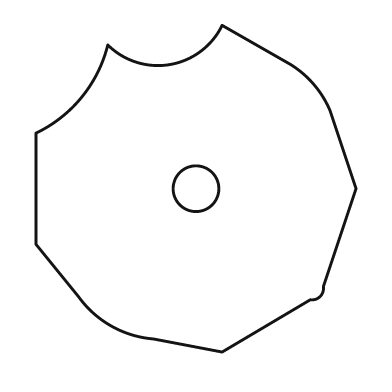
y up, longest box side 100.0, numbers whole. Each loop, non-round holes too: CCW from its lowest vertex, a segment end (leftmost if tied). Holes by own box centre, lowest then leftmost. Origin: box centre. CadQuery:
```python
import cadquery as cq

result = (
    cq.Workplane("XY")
    .moveTo(8.0, -50.0)
    .lineTo(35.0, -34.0)
    .threePointArc((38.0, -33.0), (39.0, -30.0))
    .lineTo(49.0, 0.0)
    .lineTo(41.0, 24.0)
    .threePointArc((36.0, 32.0), (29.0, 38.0))
    .lineTo(8.0, 50.0)
    .threePointArc((-8.0, 38.0), (-27.0, 44.0))
    .threePointArc((-35.0, 28.0), (-49.0, 17.0))
    .lineTo(-49.0, -17.0)
    .lineTo(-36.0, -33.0)
    .threePointArc((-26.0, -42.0), (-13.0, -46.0))
    .close()
    .moveTo(0.0, 0.0)
    .circle(7.0)
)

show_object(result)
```